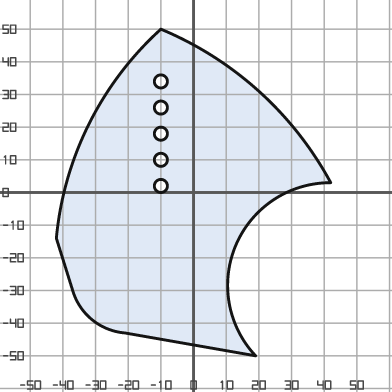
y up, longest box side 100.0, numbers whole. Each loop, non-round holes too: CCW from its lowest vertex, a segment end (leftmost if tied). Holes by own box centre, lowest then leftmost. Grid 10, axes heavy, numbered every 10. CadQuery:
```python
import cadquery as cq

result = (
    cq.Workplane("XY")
    .moveTo(19.0, -50.0)
    .threePointArc((13.0, -16.0), (42.0, 3.0))
    .threePointArc((20.0, 31.0), (-10.0, 50.0))
    .threePointArc((-32.0, 21.0), (-42.0, -14.0))
    .lineTo(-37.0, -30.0)
    .threePointArc((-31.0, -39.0), (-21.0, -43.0))
    .close()
    .moveTo(-10.0, 2.0)
    .circle(2.0)
    .moveTo(-10.0, 10.0)
    .circle(2.0)
    .moveTo(-10.0, 18.0)
    .circle(2.0)
    .moveTo(-10.0, 26.0)
    .circle(2.0)
    .moveTo(-10.0, 34.0)
    .circle(2.0)
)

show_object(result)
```